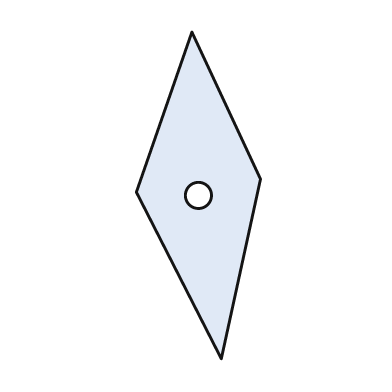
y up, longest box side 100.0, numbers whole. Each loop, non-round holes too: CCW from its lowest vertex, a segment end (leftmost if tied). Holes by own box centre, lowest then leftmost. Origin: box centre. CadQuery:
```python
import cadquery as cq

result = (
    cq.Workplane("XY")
    .moveTo(7.0, -50.0)
    .lineTo(19.0, 5.0)
    .lineTo(-2.0, 50.0)
    .lineTo(-19.0, 1.0)
    .close()
    .moveTo(0.0, 0.0)
    .circle(4.0)
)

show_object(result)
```